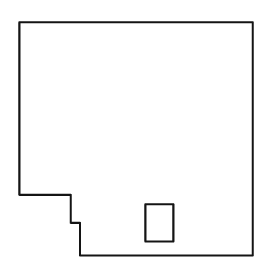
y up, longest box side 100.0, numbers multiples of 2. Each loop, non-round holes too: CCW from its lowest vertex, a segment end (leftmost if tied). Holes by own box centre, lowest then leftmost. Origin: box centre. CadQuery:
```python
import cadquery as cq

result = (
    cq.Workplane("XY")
    .moveTo(-24.0, -50.0)
    .lineTo(50.0, -50.0)
    .lineTo(50.0, 50.0)
    .lineTo(-50.0, 50.0)
    .lineTo(-50.0, -24.0)
    .lineTo(-28.0, -24.0)
    .lineTo(-28.0, -36.0)
    .lineTo(-24.0, -36.0)
    .close()
    .moveTo(4.0, -44.0)
    .lineTo(16.0, -44.0)
    .lineTo(16.0, -28.0)
    .lineTo(4.0, -28.0)
    .close()
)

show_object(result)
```